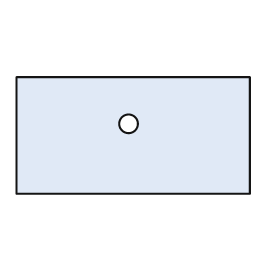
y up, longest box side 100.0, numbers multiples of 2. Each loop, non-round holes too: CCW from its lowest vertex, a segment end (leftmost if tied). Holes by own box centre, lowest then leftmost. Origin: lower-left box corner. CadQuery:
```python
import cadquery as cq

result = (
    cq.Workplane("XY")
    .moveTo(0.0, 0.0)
    .lineTo(100.0, 0.0)
    .lineTo(100.0, 50.0)
    .lineTo(0.0, 50.0)
    .close()
    .moveTo(48.0, 30.0)
    .circle(4.0)
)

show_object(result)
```